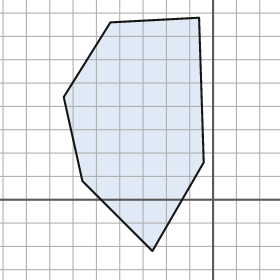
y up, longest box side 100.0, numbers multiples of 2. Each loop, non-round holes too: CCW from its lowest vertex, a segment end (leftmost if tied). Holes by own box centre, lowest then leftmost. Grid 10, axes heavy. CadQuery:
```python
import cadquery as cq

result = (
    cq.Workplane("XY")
    .moveTo(-26.0, -22.0)
    .lineTo(-4.0, 16.0)
    .lineTo(-6.0, 78.0)
    .lineTo(-44.0, 76.0)
    .lineTo(-64.0, 44.0)
    .lineTo(-56.0, 8.0)
    .close()
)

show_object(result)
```